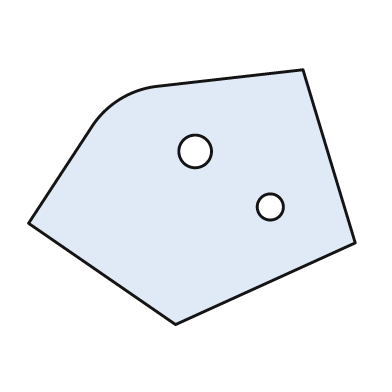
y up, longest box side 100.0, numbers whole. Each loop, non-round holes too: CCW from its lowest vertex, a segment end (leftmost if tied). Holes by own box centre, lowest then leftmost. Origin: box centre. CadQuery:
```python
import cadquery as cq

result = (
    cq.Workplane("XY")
    .moveTo(-5.0, -39.0)
    .lineTo(50.0, -14.0)
    .lineTo(34.0, 39.0)
    .lineTo(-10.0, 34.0)
    .threePointArc((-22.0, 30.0), (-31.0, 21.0))
    .lineTo(-50.0, -8.0)
    .close()
    .moveTo(24.0, -3.0)
    .circle(4.0)
    .moveTo(1.0, 14.0)
    .circle(5.0)
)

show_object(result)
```